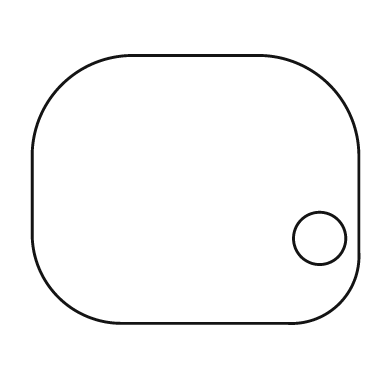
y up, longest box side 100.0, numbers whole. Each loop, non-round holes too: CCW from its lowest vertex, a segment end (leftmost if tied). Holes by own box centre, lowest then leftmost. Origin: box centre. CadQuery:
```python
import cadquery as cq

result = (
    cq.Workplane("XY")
    .moveTo(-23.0, -41.0)
    .lineTo(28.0, -41.0)
    .threePointArc((44.0, -35.0), (50.0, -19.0))
    .lineTo(50.0, 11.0)
    .threePointArc((41.0, 32.0), (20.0, 41.0))
    .lineTo(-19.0, 41.0)
    .threePointArc((-41.0, 32.0), (-50.0, 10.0))
    .lineTo(-50.0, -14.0)
    .threePointArc((-42.0, -33.0), (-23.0, -41.0))
    .close()
    .moveTo(38.0, -15.0)
    .circle(8.0)
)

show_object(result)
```